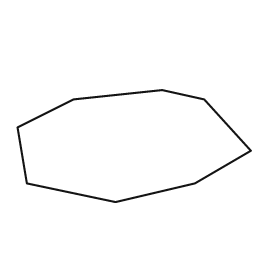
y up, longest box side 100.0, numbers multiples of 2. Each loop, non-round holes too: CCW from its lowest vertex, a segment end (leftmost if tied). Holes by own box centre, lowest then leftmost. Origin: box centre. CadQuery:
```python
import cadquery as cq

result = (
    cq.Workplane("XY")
    .moveTo(-8.0, -24.0)
    .lineTo(26.0, -16.0)
    .lineTo(50.0, -2.0)
    .lineTo(30.0, 20.0)
    .lineTo(12.0, 24.0)
    .lineTo(-26.0, 20.0)
    .lineTo(-50.0, 8.0)
    .lineTo(-46.0, -16.0)
    .close()
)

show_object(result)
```